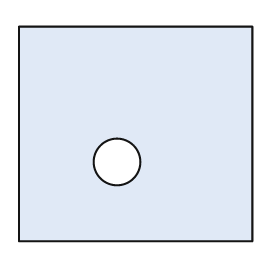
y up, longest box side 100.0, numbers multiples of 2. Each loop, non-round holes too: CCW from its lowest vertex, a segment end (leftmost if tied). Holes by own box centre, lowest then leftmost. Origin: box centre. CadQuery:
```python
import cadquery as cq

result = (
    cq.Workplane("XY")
    .moveTo(-50.0, -46.0)
    .lineTo(50.0, -46.0)
    .lineTo(50.0, 46.0)
    .lineTo(-50.0, 46.0)
    .close()
    .moveTo(-8.0, -12.0)
    .circle(10.0)
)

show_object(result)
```